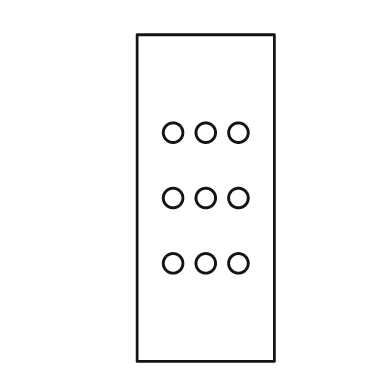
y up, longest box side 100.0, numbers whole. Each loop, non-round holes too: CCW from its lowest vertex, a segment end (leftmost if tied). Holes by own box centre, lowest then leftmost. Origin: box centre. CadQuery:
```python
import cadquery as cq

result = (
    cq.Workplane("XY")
    .moveTo(-21.0, -50.0)
    .lineTo(21.0, -50.0)
    .lineTo(21.0, 50.0)
    .lineTo(-21.0, 50.0)
    .close()
    .moveTo(-10.0, -20.0)
    .circle(3.0)
    .moveTo(0.0, -20.0)
    .circle(3.0)
    .moveTo(10.0, -20.0)
    .circle(3.0)
    .moveTo(-10.0, 0.0)
    .circle(3.0)
    .moveTo(0.0, 0.0)
    .circle(3.0)
    .moveTo(10.0, 0.0)
    .circle(3.0)
    .moveTo(-10.0, 20.0)
    .circle(3.0)
    .moveTo(0.0, 20.0)
    .circle(3.0)
    .moveTo(10.0, 20.0)
    .circle(3.0)
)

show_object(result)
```